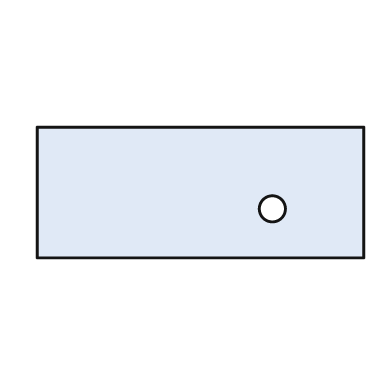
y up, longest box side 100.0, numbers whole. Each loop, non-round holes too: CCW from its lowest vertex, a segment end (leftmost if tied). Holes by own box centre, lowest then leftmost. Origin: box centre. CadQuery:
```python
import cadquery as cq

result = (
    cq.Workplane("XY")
    .moveTo(-50.0, -20.0)
    .lineTo(50.0, -20.0)
    .lineTo(50.0, 20.0)
    .lineTo(-50.0, 20.0)
    .close()
    .moveTo(22.0, -5.0)
    .circle(4.0)
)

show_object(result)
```